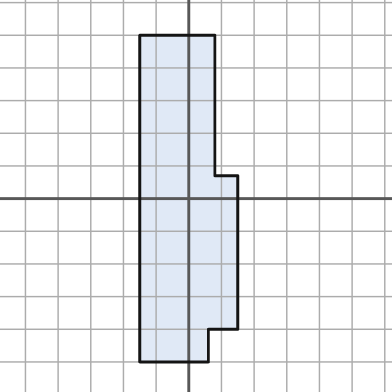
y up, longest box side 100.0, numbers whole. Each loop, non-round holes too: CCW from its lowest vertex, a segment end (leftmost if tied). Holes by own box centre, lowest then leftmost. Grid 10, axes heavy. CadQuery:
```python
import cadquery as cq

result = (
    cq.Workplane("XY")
    .moveTo(-15.0, -50.0)
    .lineTo(6.0, -50.0)
    .lineTo(6.0, -40.0)
    .lineTo(15.0, -40.0)
    .lineTo(15.0, 7.0)
    .lineTo(8.0, 7.0)
    .lineTo(8.0, 50.0)
    .lineTo(-15.0, 50.0)
    .close()
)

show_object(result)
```